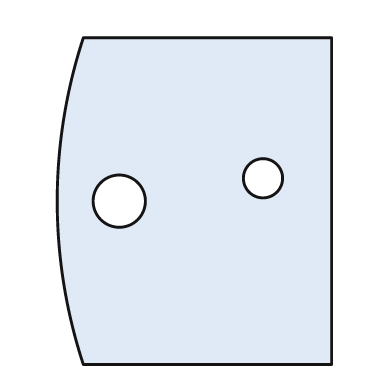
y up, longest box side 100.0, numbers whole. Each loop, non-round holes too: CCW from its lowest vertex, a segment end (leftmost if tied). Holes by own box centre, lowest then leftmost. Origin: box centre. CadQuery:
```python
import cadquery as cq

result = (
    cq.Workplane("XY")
    .moveTo(-34.0, -50.0)
    .lineTo(42.0, -50.0)
    .lineTo(42.0, 50.0)
    .lineTo(-34.0, 50.0)
    .threePointArc((-42.0, 0.0), (-34.0, -50.0))
    .close()
    .moveTo(-23.0, 0.0)
    .circle(8.0)
    .moveTo(21.0, 7.0)
    .circle(6.0)
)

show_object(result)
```